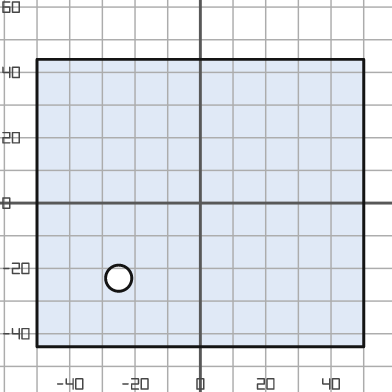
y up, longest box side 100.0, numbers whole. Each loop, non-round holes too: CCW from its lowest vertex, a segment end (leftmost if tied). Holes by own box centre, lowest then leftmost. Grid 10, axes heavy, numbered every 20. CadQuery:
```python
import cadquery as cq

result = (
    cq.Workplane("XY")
    .moveTo(-50.0, -44.0)
    .lineTo(50.0, -44.0)
    .lineTo(50.0, 44.0)
    .lineTo(-50.0, 44.0)
    .close()
    .moveTo(-25.0, -23.0)
    .circle(4.0)
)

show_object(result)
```